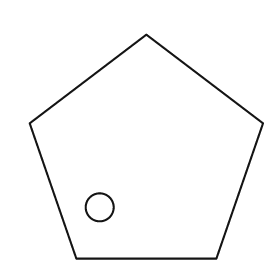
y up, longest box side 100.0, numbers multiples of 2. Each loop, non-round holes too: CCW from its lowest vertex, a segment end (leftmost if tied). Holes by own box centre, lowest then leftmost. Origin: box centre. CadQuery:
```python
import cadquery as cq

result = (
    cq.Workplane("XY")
    .moveTo(-30.0, -48.0)
    .lineTo(30.0, -48.0)
    .lineTo(50.0, 10.0)
    .lineTo(0.0, 48.0)
    .lineTo(-50.0, 10.0)
    .close()
    .moveTo(-20.0, -26.0)
    .circle(6.0)
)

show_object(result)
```